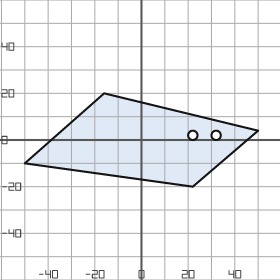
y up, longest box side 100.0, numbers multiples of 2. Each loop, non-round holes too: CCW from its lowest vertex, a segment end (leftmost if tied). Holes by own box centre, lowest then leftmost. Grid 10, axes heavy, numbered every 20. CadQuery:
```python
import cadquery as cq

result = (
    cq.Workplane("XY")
    .moveTo(22.0, -20.0)
    .lineTo(50.0, 4.0)
    .lineTo(-16.0, 20.0)
    .lineTo(-50.0, -10.0)
    .close()
    .moveTo(22.0, 2.0)
    .circle(2.0)
    .moveTo(32.0, 2.0)
    .circle(2.0)
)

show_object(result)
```